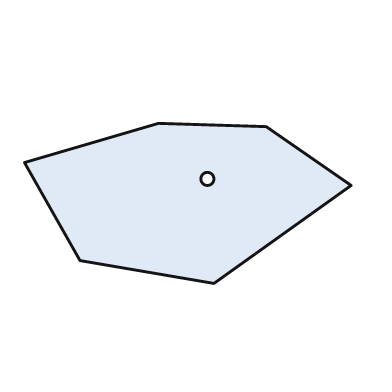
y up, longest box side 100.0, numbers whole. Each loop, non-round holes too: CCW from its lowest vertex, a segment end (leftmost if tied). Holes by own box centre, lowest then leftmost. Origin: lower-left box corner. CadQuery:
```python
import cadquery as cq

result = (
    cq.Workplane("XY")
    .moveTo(58.0, 0.0)
    .lineTo(100.0, 30.0)
    .lineTo(74.0, 48.0)
    .lineTo(41.0, 49.0)
    .lineTo(0.0, 37.0)
    .lineTo(17.0, 7.0)
    .close()
    .moveTo(56.0, 32.0)
    .circle(2.0)
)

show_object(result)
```